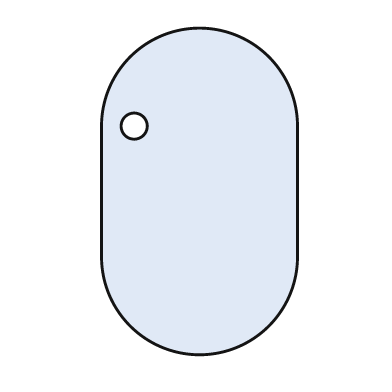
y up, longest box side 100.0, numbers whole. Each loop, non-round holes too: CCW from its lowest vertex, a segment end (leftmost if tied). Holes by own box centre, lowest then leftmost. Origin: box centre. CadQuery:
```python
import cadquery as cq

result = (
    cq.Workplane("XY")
    .moveTo(-30.0, -20.0)
    .threePointArc((0.0, -50.0), (30.0, -20.0))
    .lineTo(30.0, 20.0)
    .threePointArc((0.0, 50.0), (-30.0, 20.0))
    .close()
    .moveTo(-20.0, 20.0)
    .circle(4.0)
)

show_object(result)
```